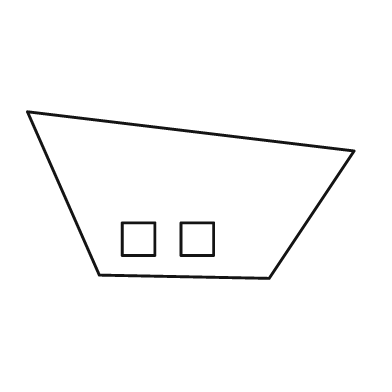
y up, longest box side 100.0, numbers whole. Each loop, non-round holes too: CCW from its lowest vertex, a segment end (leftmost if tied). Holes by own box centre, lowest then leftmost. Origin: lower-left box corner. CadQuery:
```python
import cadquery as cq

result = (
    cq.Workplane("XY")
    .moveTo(74.0, 0.0)
    .lineTo(100.0, 39.0)
    .lineTo(0.0, 51.0)
    .lineTo(22.0, 1.0)
    .close()
    .moveTo(29.0, 7.0)
    .lineTo(39.0, 7.0)
    .lineTo(39.0, 17.0)
    .lineTo(29.0, 17.0)
    .close()
    .moveTo(47.0, 7.0)
    .lineTo(57.0, 7.0)
    .lineTo(57.0, 17.0)
    .lineTo(47.0, 17.0)
    .close()
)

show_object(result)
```